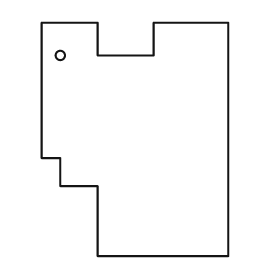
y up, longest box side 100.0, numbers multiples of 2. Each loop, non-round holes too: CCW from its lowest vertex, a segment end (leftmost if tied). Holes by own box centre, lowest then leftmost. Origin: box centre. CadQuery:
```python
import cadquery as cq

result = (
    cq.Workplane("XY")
    .moveTo(-16.0, -50.0)
    .lineTo(40.0, -50.0)
    .lineTo(40.0, 50.0)
    .lineTo(8.0, 50.0)
    .lineTo(8.0, 36.0)
    .lineTo(-16.0, 36.0)
    .lineTo(-16.0, 50.0)
    .lineTo(-40.0, 50.0)
    .lineTo(-40.0, -8.0)
    .lineTo(-32.0, -8.0)
    .lineTo(-32.0, -20.0)
    .lineTo(-16.0, -20.0)
    .close()
    .moveTo(-32.0, 36.0)
    .circle(2.0)
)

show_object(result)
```